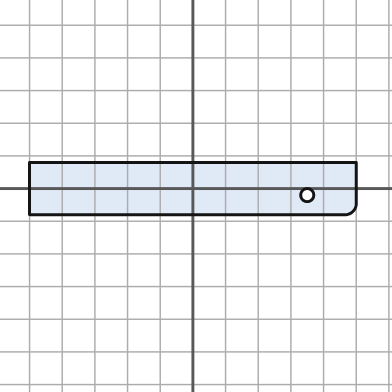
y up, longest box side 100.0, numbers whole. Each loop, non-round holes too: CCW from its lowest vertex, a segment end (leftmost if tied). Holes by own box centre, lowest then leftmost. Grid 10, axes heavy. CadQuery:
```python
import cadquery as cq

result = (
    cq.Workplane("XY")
    .moveTo(-50.0, -8.0)
    .lineTo(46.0, -8.0)
    .threePointArc((49.0, -7.0), (50.0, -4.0))
    .lineTo(50.0, 8.0)
    .lineTo(-50.0, 8.0)
    .close()
    .moveTo(35.0, -2.0)
    .circle(2.0)
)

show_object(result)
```